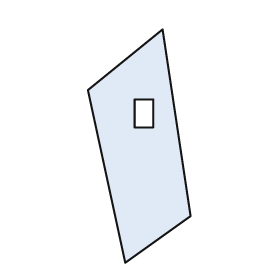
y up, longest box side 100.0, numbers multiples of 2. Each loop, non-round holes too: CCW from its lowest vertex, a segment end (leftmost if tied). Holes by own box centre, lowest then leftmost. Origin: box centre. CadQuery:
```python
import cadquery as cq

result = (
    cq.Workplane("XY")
    .moveTo(-6.0, -50.0)
    .lineTo(22.0, -30.0)
    .lineTo(10.0, 50.0)
    .lineTo(-22.0, 24.0)
    .close()
    .moveTo(-2.0, 8.0)
    .lineTo(6.0, 8.0)
    .lineTo(6.0, 20.0)
    .lineTo(-2.0, 20.0)
    .close()
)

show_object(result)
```